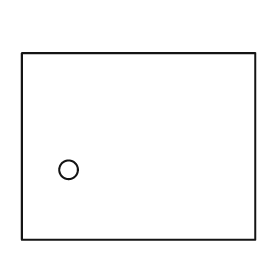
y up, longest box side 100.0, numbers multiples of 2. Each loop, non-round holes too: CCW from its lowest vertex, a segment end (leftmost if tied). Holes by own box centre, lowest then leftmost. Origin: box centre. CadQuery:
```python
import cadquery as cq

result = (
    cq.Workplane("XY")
    .moveTo(-50.0, -40.0)
    .lineTo(50.0, -40.0)
    .lineTo(50.0, 40.0)
    .lineTo(-50.0, 40.0)
    .close()
    .moveTo(-30.0, -10.0)
    .circle(4.0)
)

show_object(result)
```